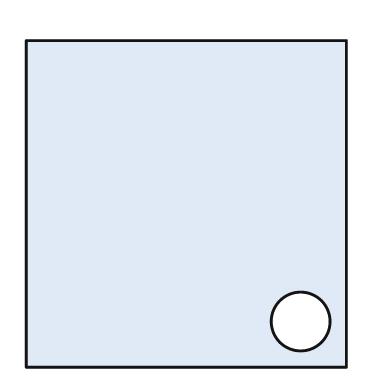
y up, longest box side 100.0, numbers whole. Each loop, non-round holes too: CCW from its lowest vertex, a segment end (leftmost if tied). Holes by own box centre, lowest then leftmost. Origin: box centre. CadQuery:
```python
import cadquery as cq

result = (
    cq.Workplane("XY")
    .moveTo(-49.0, -50.0)
    .lineTo(49.0, -50.0)
    .lineTo(49.0, 50.0)
    .lineTo(-49.0, 50.0)
    .close()
    .moveTo(35.0, -36.0)
    .circle(9.0)
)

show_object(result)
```